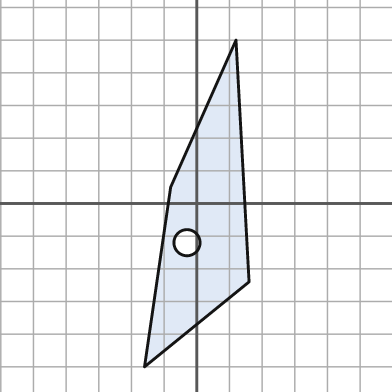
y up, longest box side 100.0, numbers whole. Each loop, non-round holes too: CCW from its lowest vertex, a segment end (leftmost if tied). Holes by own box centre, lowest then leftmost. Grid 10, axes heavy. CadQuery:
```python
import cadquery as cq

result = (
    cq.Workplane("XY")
    .moveTo(-16.0, -50.0)
    .lineTo(16.0, -24.0)
    .lineTo(12.0, 50.0)
    .lineTo(-8.0, 5.0)
    .close()
    .moveTo(-3.0, -12.0)
    .circle(4.0)
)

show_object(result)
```